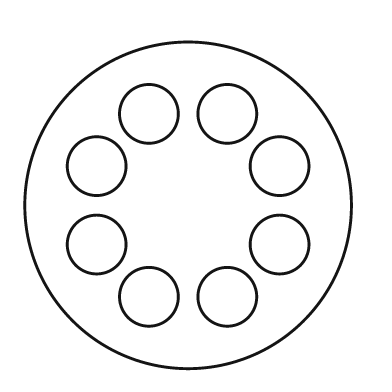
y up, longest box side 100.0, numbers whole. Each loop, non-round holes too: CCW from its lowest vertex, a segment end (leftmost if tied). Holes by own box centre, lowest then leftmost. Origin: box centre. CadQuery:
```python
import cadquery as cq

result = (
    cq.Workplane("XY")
    .moveTo(0.0, 0.0)
    .circle(50.0)
    .moveTo(-12.0, -28.0)
    .circle(9.0)
    .moveTo(12.0, -28.0)
    .circle(9.0)
    .moveTo(-28.0, -12.0)
    .circle(9.0)
    .moveTo(28.0, -12.0)
    .circle(9.0)
    .moveTo(-28.0, 12.0)
    .circle(9.0)
    .moveTo(28.0, 12.0)
    .circle(9.0)
    .moveTo(-12.0, 28.0)
    .circle(9.0)
    .moveTo(12.0, 28.0)
    .circle(9.0)
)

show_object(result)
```